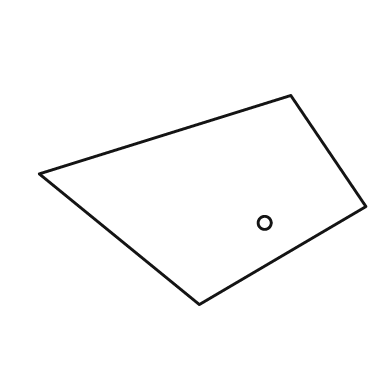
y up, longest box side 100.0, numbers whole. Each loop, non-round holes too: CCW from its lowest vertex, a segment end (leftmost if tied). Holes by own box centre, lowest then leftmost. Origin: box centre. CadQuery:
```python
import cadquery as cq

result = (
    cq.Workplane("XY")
    .moveTo(-1.0, -32.0)
    .lineTo(50.0, -2.0)
    .lineTo(27.0, 32.0)
    .lineTo(-50.0, 8.0)
    .close()
    .moveTo(19.0, -7.0)
    .circle(2.0)
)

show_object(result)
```